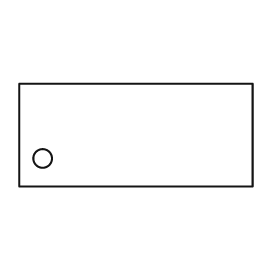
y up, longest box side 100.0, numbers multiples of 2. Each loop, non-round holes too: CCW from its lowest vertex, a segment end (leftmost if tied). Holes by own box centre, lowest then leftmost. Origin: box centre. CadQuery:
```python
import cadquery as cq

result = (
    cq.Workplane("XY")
    .moveTo(-50.0, -22.0)
    .lineTo(50.0, -22.0)
    .lineTo(50.0, 22.0)
    .lineTo(-50.0, 22.0)
    .close()
    .moveTo(-40.0, -10.0)
    .circle(4.0)
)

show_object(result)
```